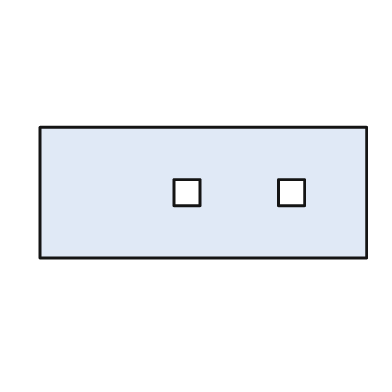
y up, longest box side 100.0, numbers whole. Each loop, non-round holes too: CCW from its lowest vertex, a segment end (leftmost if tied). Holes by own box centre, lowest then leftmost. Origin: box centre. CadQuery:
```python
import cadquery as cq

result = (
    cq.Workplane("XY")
    .moveTo(-50.0, -20.0)
    .lineTo(50.0, -20.0)
    .lineTo(50.0, 20.0)
    .lineTo(-50.0, 20.0)
    .close()
    .moveTo(-9.0, -4.0)
    .lineTo(-1.0, -4.0)
    .lineTo(-1.0, 4.0)
    .lineTo(-9.0, 4.0)
    .close()
    .moveTo(23.0, -4.0)
    .lineTo(31.0, -4.0)
    .lineTo(31.0, 4.0)
    .lineTo(23.0, 4.0)
    .close()
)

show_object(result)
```